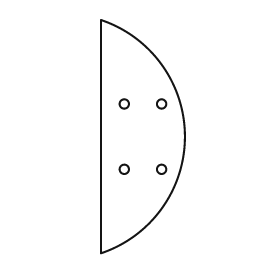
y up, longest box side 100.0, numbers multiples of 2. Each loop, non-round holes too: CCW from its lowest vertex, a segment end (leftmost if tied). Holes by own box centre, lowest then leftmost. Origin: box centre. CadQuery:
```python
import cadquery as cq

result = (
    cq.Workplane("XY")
    .moveTo(-18.0, -50.0)
    .threePointArc((18.0, 0.0), (-18.0, 50.0))
    .close()
    .moveTo(-8.0, -14.0)
    .circle(2.0)
    .moveTo(8.0, -14.0)
    .circle(2.0)
    .moveTo(-8.0, 14.0)
    .circle(2.0)
    .moveTo(8.0, 14.0)
    .circle(2.0)
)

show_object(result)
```